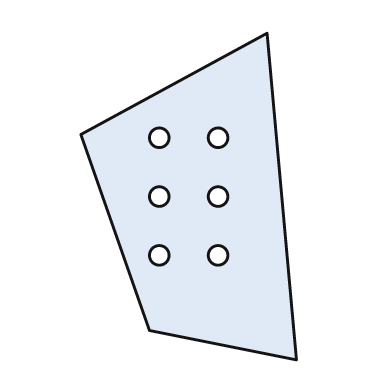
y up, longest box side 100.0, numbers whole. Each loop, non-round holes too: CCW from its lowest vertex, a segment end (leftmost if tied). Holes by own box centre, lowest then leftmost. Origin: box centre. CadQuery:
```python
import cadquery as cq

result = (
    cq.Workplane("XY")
    .moveTo(33.0, -50.0)
    .lineTo(24.0, 50.0)
    .lineTo(-33.0, 19.0)
    .lineTo(-12.0, -41.0)
    .close()
    .moveTo(-9.0, -18.0)
    .circle(3.0)
    .moveTo(9.0, -18.0)
    .circle(3.0)
    .moveTo(-9.0, 0.0)
    .circle(3.0)
    .moveTo(9.0, 0.0)
    .circle(3.0)
    .moveTo(-9.0, 18.0)
    .circle(3.0)
    .moveTo(9.0, 18.0)
    .circle(3.0)
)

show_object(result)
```